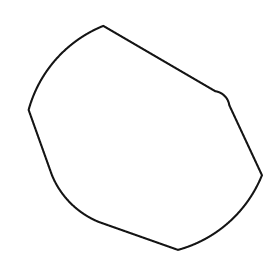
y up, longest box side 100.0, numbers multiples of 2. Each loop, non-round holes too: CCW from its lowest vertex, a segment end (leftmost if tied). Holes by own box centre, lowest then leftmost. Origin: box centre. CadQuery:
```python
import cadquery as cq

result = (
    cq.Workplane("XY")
    .moveTo(14.0, -48.0)
    .threePointArc((36.0, -36.0), (50.0, -16.0))
    .lineTo(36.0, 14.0)
    .threePointArc((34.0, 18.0), (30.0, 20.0))
    .lineTo(-18.0, 48.0)
    .threePointArc((-38.0, 34.0), (-50.0, 12.0))
    .lineTo(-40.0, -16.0)
    .threePointArc((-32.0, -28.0), (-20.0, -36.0))
    .close()
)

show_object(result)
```